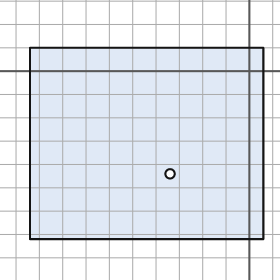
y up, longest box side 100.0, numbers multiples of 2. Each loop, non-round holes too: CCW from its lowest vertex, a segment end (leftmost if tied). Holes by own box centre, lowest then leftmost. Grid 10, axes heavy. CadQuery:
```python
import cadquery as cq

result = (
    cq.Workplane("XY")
    .moveTo(-94.0, -72.0)
    .lineTo(6.0, -72.0)
    .lineTo(6.0, 10.0)
    .lineTo(-94.0, 10.0)
    .close()
    .moveTo(-34.0, -44.0)
    .circle(2.0)
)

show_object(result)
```